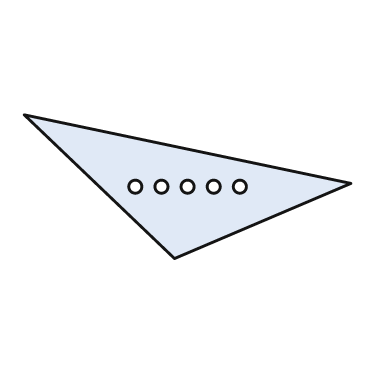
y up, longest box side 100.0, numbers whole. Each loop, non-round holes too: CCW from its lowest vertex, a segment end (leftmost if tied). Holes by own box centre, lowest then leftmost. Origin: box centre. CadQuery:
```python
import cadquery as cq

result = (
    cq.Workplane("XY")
    .moveTo(-4.0, -22.0)
    .lineTo(50.0, 1.0)
    .lineTo(-50.0, 22.0)
    .close()
    .moveTo(-16.0, 0.0)
    .circle(2.0)
    .moveTo(-8.0, 0.0)
    .circle(2.0)
    .moveTo(0.0, 0.0)
    .circle(2.0)
    .moveTo(8.0, 0.0)
    .circle(2.0)
    .moveTo(16.0, 0.0)
    .circle(2.0)
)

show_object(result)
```